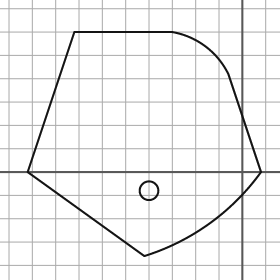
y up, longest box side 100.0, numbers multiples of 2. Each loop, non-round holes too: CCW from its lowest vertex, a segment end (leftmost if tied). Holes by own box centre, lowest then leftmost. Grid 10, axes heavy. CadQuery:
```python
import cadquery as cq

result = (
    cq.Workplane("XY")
    .moveTo(-42.0, -36.0)
    .threePointArc((-14.0, -22.0), (8.0, 0.0))
    .lineTo(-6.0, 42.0)
    .threePointArc((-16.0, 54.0), (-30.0, 60.0))
    .lineTo(-72.0, 60.0)
    .lineTo(-92.0, 0.0)
    .close()
    .moveTo(-40.0, -8.0)
    .circle(4.0)
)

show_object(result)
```